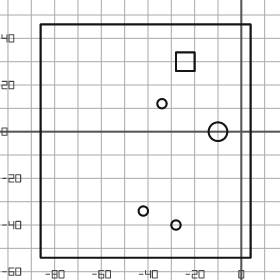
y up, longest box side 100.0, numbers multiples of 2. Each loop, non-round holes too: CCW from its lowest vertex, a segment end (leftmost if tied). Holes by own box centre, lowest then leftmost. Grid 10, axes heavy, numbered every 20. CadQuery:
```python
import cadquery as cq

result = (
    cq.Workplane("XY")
    .moveTo(-86.0, -54.0)
    .lineTo(4.0, -54.0)
    .lineTo(4.0, 46.0)
    .lineTo(-86.0, 46.0)
    .close()
    .moveTo(-28.0, -40.0)
    .circle(2.0)
    .moveTo(-42.0, -34.0)
    .circle(2.0)
    .moveTo(-10.0, 0.0)
    .circle(4.0)
    .moveTo(-34.0, 12.0)
    .circle(2.0)
    .moveTo(-28.0, 26.0)
    .lineTo(-20.0, 26.0)
    .lineTo(-20.0, 34.0)
    .lineTo(-28.0, 34.0)
    .close()
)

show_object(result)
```